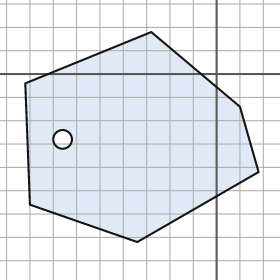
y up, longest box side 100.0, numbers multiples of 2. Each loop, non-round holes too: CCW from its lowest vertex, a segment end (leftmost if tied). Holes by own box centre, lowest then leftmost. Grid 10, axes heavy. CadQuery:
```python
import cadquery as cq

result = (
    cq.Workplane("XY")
    .moveTo(-34.0, -72.0)
    .lineTo(18.0, -42.0)
    .lineTo(10.0, -14.0)
    .lineTo(-28.0, 18.0)
    .lineTo(-82.0, -4.0)
    .lineTo(-80.0, -56.0)
    .close()
    .moveTo(-66.0, -28.0)
    .circle(4.0)
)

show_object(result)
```